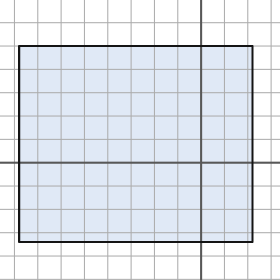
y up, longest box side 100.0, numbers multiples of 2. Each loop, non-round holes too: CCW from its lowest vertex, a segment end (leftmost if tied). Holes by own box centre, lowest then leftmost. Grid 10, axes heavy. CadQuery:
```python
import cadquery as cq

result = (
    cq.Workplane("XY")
    .moveTo(-78.0, -34.0)
    .lineTo(22.0, -34.0)
    .lineTo(22.0, 50.0)
    .lineTo(-78.0, 50.0)
    .close()
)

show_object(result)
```